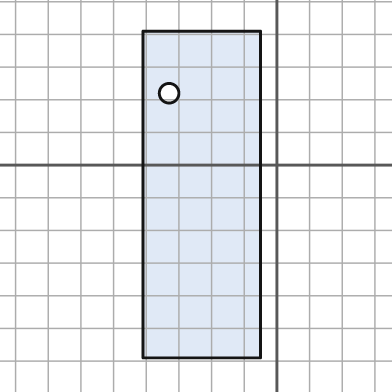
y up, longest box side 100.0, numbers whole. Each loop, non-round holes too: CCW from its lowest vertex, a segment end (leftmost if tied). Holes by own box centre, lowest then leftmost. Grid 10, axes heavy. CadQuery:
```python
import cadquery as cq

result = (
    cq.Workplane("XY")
    .moveTo(-41.0, -59.0)
    .lineTo(-5.0, -59.0)
    .lineTo(-5.0, 41.0)
    .lineTo(-41.0, 41.0)
    .close()
    .moveTo(-33.0, 22.0)
    .circle(3.0)
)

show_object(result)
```